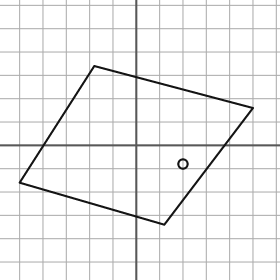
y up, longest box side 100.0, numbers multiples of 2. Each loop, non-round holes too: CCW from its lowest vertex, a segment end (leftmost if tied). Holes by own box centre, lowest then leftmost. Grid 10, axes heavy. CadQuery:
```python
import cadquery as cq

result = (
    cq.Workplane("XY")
    .moveTo(12.0, -34.0)
    .lineTo(50.0, 16.0)
    .lineTo(-18.0, 34.0)
    .lineTo(-50.0, -16.0)
    .close()
    .moveTo(20.0, -8.0)
    .circle(2.0)
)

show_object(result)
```